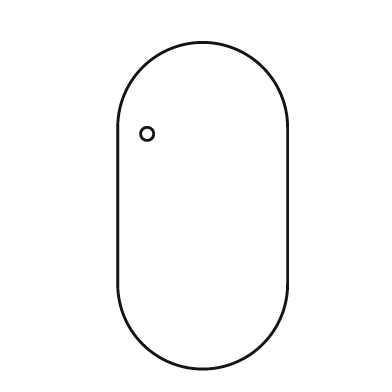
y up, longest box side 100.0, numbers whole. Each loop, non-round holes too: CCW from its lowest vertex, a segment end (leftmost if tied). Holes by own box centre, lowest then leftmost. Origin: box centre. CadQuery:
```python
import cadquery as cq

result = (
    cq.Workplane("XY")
    .moveTo(-26.0, -24.0)
    .threePointArc((0.0, -50.0), (26.0, -24.0))
    .lineTo(26.0, 24.0)
    .threePointArc((0.0, 50.0), (-26.0, 24.0))
    .close()
    .moveTo(-17.0, 22.0)
    .circle(2.0)
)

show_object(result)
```